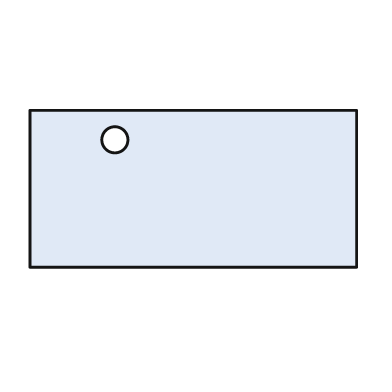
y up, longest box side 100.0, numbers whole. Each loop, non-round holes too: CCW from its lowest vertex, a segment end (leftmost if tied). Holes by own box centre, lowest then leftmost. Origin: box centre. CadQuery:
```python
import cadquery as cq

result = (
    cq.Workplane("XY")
    .moveTo(-50.0, -24.0)
    .lineTo(50.0, -24.0)
    .lineTo(50.0, 24.0)
    .lineTo(-50.0, 24.0)
    .close()
    .moveTo(-24.0, 15.0)
    .circle(4.0)
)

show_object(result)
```